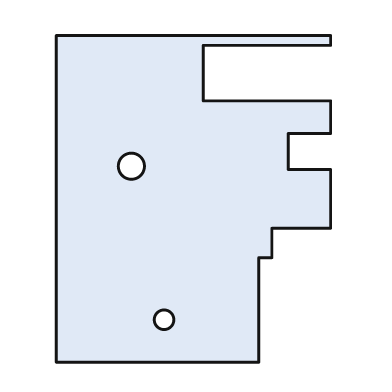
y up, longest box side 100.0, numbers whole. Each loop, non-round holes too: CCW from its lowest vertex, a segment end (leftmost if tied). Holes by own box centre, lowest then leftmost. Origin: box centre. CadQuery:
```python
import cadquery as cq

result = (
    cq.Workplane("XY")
    .moveTo(-42.0, -50.0)
    .lineTo(20.0, -50.0)
    .lineTo(20.0, -18.0)
    .lineTo(24.0, -18.0)
    .lineTo(24.0, -9.0)
    .lineTo(42.0, -9.0)
    .lineTo(42.0, 9.0)
    .lineTo(29.0, 9.0)
    .lineTo(29.0, 20.0)
    .lineTo(42.0, 20.0)
    .lineTo(42.0, 30.0)
    .lineTo(3.0, 30.0)
    .lineTo(3.0, 47.0)
    .lineTo(42.0, 47.0)
    .lineTo(42.0, 50.0)
    .lineTo(-42.0, 50.0)
    .close()
    .moveTo(-9.0, -37.0)
    .circle(3.0)
    .moveTo(-19.0, 10.0)
    .circle(4.0)
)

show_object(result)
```